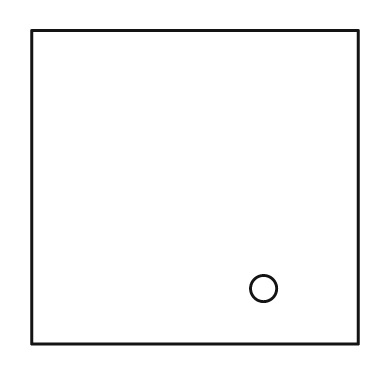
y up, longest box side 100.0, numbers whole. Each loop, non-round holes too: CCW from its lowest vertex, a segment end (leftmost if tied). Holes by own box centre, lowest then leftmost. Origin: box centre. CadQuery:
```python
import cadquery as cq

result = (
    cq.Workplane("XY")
    .moveTo(-50.0, -48.0)
    .lineTo(50.0, -48.0)
    .lineTo(50.0, 48.0)
    .lineTo(-50.0, 48.0)
    .close()
    .moveTo(21.0, -31.0)
    .circle(4.0)
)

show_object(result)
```